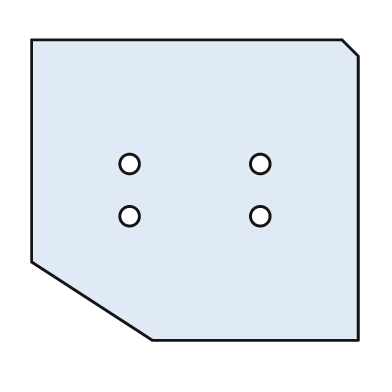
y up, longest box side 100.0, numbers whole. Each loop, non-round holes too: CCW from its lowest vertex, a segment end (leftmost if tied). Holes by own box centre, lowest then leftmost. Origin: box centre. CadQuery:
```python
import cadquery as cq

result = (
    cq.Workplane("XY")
    .moveTo(-13.0, -46.0)
    .lineTo(50.0, -46.0)
    .lineTo(50.0, 41.0)
    .lineTo(45.0, 46.0)
    .lineTo(-50.0, 46.0)
    .lineTo(-50.0, -22.0)
    .close()
    .moveTo(-20.0, -8.0)
    .circle(3.0)
    .moveTo(20.0, -8.0)
    .circle(3.0)
    .moveTo(-20.0, 8.0)
    .circle(3.0)
    .moveTo(20.0, 8.0)
    .circle(3.0)
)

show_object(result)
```